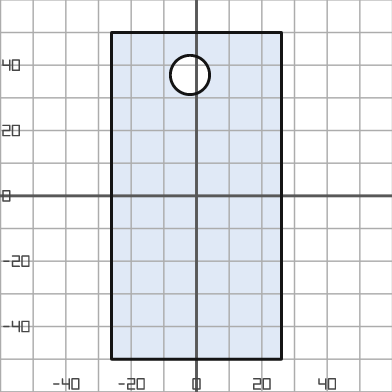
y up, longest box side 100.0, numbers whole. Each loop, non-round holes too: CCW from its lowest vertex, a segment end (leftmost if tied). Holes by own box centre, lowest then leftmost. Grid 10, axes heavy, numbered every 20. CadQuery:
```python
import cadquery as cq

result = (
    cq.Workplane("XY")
    .moveTo(-26.0, -50.0)
    .lineTo(26.0, -50.0)
    .lineTo(26.0, 50.0)
    .lineTo(-26.0, 50.0)
    .close()
    .moveTo(-2.0, 37.0)
    .circle(6.0)
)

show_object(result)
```